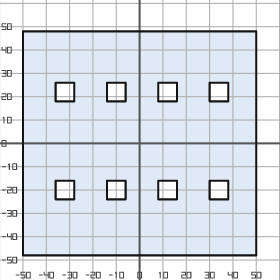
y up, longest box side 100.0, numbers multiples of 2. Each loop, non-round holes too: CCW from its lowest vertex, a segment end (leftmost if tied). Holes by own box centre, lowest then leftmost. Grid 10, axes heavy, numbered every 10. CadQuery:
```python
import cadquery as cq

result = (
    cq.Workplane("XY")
    .moveTo(-50.0, -48.0)
    .lineTo(50.0, -48.0)
    .lineTo(50.0, 48.0)
    .lineTo(-50.0, 48.0)
    .close()
    .moveTo(-36.0, -24.0)
    .lineTo(-28.0, -24.0)
    .lineTo(-28.0, -16.0)
    .lineTo(-36.0, -16.0)
    .close()
    .moveTo(-14.0, -24.0)
    .lineTo(-6.0, -24.0)
    .lineTo(-6.0, -16.0)
    .lineTo(-14.0, -16.0)
    .close()
    .moveTo(8.0, -24.0)
    .lineTo(16.0, -24.0)
    .lineTo(16.0, -16.0)
    .lineTo(8.0, -16.0)
    .close()
    .moveTo(30.0, -24.0)
    .lineTo(38.0, -24.0)
    .lineTo(38.0, -16.0)
    .lineTo(30.0, -16.0)
    .close()
    .moveTo(-36.0, 18.0)
    .lineTo(-28.0, 18.0)
    .lineTo(-28.0, 26.0)
    .lineTo(-36.0, 26.0)
    .close()
    .moveTo(-14.0, 18.0)
    .lineTo(-6.0, 18.0)
    .lineTo(-6.0, 26.0)
    .lineTo(-14.0, 26.0)
    .close()
    .moveTo(8.0, 18.0)
    .lineTo(16.0, 18.0)
    .lineTo(16.0, 26.0)
    .lineTo(8.0, 26.0)
    .close()
    .moveTo(30.0, 18.0)
    .lineTo(38.0, 18.0)
    .lineTo(38.0, 26.0)
    .lineTo(30.0, 26.0)
    .close()
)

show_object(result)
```